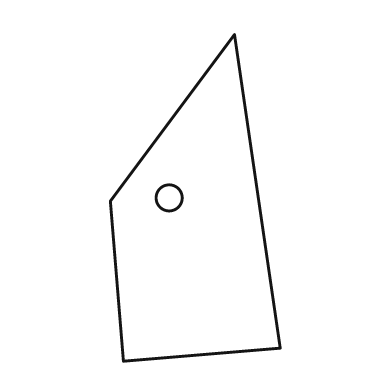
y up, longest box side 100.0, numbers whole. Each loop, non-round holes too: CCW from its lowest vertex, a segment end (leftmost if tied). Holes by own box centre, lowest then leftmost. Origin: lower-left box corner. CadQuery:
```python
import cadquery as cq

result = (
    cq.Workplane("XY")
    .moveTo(4.0, 0.0)
    .lineTo(52.0, 4.0)
    .lineTo(38.0, 100.0)
    .lineTo(0.0, 49.0)
    .close()
    .moveTo(18.0, 50.0)
    .circle(4.0)
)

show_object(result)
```